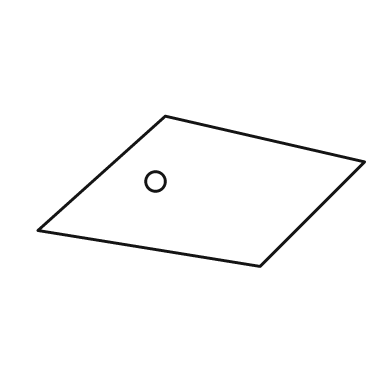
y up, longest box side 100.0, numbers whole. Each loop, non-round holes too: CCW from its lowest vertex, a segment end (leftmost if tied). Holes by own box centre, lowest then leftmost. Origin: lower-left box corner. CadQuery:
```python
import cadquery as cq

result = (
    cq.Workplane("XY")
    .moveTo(68.0, 0.0)
    .lineTo(100.0, 32.0)
    .lineTo(39.0, 46.0)
    .lineTo(0.0, 11.0)
    .close()
    .moveTo(36.0, 26.0)
    .circle(3.0)
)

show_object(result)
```